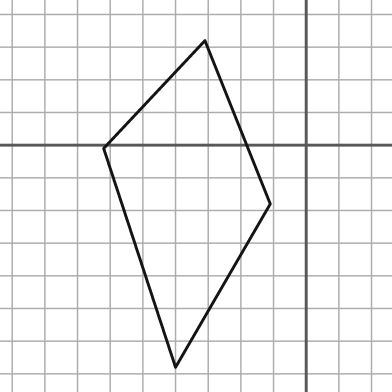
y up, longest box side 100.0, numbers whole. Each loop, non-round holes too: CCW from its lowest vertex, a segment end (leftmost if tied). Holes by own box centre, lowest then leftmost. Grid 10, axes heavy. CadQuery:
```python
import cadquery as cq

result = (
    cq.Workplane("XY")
    .moveTo(-40.0, -68.0)
    .lineTo(-11.0, -18.0)
    .lineTo(-31.0, 32.0)
    .lineTo(-62.0, -1.0)
    .close()
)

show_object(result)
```